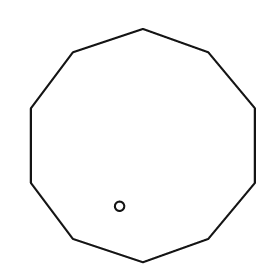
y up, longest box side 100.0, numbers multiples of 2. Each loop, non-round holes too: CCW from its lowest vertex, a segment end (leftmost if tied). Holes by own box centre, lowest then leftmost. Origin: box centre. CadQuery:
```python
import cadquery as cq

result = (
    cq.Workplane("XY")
    .moveTo(0.0, -50.0)
    .lineTo(28.0, -40.0)
    .lineTo(48.0, -16.0)
    .lineTo(48.0, 16.0)
    .lineTo(28.0, 40.0)
    .lineTo(0.0, 50.0)
    .lineTo(-30.0, 40.0)
    .lineTo(-48.0, 16.0)
    .lineTo(-48.0, -16.0)
    .lineTo(-30.0, -40.0)
    .close()
    .moveTo(-10.0, -26.0)
    .circle(2.0)
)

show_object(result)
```